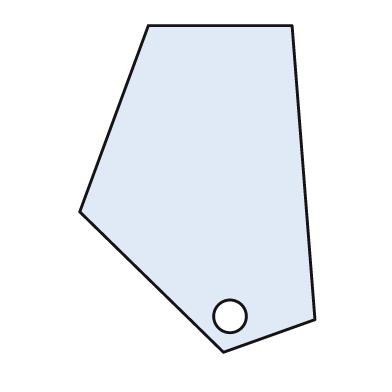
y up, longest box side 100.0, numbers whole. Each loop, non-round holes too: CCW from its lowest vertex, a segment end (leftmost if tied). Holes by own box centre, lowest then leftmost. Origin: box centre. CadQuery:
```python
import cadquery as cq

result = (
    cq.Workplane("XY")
    .moveTo(8.0, -50.0)
    .lineTo(36.0, -40.0)
    .lineTo(29.0, 50.0)
    .lineTo(-15.0, 50.0)
    .lineTo(-36.0, -7.0)
    .close()
    .moveTo(10.0, -39.0)
    .circle(5.0)
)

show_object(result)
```